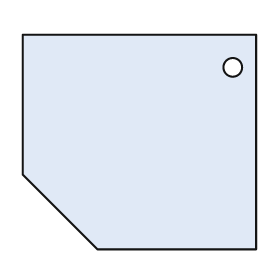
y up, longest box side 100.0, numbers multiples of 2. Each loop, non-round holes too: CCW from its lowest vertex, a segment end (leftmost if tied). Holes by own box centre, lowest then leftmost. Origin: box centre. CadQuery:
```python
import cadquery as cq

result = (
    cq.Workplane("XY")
    .moveTo(-18.0, -46.0)
    .lineTo(50.0, -46.0)
    .lineTo(50.0, 46.0)
    .lineTo(-50.0, 46.0)
    .lineTo(-50.0, -14.0)
    .close()
    .moveTo(40.0, 32.0)
    .circle(4.0)
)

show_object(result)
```